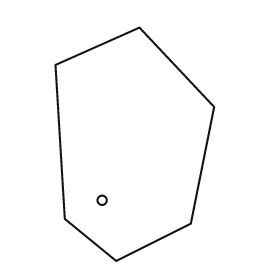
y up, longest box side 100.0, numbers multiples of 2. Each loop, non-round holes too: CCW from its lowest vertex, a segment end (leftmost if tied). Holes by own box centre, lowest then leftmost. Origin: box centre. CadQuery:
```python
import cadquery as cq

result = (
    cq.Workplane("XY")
    .moveTo(-8.0, -50.0)
    .lineTo(24.0, -34.0)
    .lineTo(34.0, 16.0)
    .lineTo(2.0, 50.0)
    .lineTo(-34.0, 34.0)
    .lineTo(-30.0, -32.0)
    .close()
    .moveTo(-14.0, -24.0)
    .circle(2.0)
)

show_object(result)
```